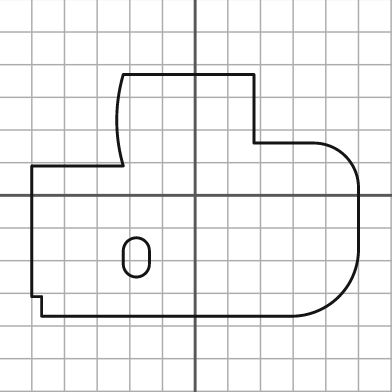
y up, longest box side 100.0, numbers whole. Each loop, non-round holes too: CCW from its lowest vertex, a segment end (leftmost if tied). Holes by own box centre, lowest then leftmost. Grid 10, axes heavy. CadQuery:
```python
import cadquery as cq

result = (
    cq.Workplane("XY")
    .moveTo(-47.0, -37.0)
    .lineTo(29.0, -37.0)
    .threePointArc((44.0, -31.0), (50.0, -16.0))
    .lineTo(50.0, 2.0)
    .threePointArc((46.0, 12.0), (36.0, 16.0))
    .lineTo(18.0, 16.0)
    .lineTo(18.0, 37.0)
    .lineTo(-22.0, 37.0)
    .threePointArc((-24.0, 23.0), (-22.0, 9.0))
    .lineTo(-50.0, 9.0)
    .lineTo(-50.0, -31.0)
    .lineTo(-47.0, -31.0)
    .close()
    .moveTo(-22.0, -21.0)
    .threePointArc((-18.0, -25.0), (-14.0, -21.0))
    .lineTo(-14.0, -17.0)
    .threePointArc((-18.0, -13.0), (-22.0, -17.0))
    .close()
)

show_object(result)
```